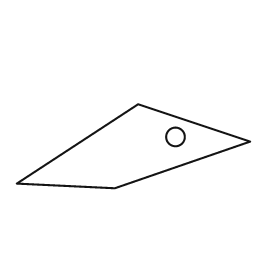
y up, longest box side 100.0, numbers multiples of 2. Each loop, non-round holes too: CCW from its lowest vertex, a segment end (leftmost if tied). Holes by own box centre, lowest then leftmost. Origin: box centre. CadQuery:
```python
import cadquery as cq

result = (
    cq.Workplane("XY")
    .moveTo(-8.0, -18.0)
    .lineTo(50.0, 2.0)
    .lineTo(2.0, 18.0)
    .lineTo(-50.0, -16.0)
    .close()
    .moveTo(18.0, 4.0)
    .circle(4.0)
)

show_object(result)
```